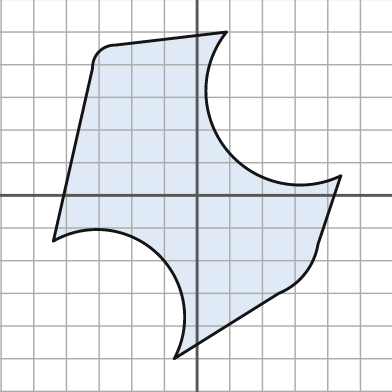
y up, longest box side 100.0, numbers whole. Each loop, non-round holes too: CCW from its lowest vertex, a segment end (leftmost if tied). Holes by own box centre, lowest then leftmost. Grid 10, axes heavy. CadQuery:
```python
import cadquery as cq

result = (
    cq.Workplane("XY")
    .moveTo(-7.0, -50.0)
    .lineTo(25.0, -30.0)
    .threePointArc((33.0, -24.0), (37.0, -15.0))
    .lineTo(44.0, 6.0)
    .threePointArc((9.0, 14.0), (9.0, 50.0))
    .lineTo(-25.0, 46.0)
    .threePointArc((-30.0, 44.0), (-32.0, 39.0))
    .lineTo(-44.0, -14.0)
    .threePointArc((-12.0, -18.0), (-7.0, -50.0))
    .close()
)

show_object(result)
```